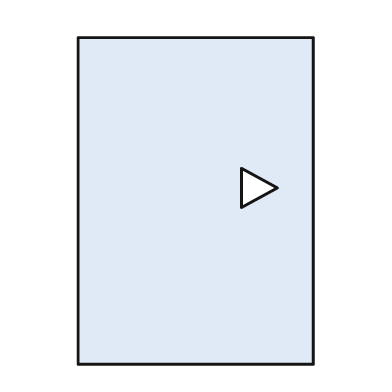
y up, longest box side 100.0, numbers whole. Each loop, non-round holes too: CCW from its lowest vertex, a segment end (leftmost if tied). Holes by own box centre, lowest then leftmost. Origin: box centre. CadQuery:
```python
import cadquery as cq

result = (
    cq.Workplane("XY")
    .moveTo(-36.0, -50.0)
    .lineTo(36.0, -50.0)
    .lineTo(36.0, 50.0)
    .lineTo(-36.0, 50.0)
    .close()
    .moveTo(14.0, -2.0)
    .lineTo(25.0, 4.0)
    .lineTo(14.0, 10.0)
    .close()
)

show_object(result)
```